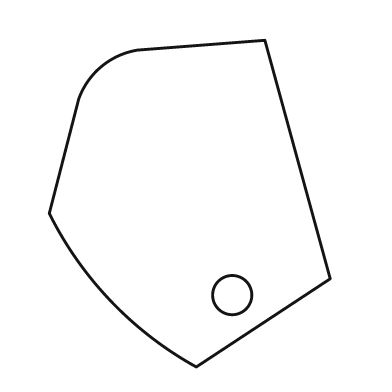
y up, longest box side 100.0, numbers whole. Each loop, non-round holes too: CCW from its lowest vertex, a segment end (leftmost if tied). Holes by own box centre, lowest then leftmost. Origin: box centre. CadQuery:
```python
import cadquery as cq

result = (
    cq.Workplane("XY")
    .moveTo(2.0, -50.0)
    .lineTo(43.0, -23.0)
    .lineTo(23.0, 50.0)
    .lineTo(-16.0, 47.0)
    .threePointArc((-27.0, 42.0), (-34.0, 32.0))
    .lineTo(-43.0, -3.0)
    .threePointArc((-24.0, -30.0), (2.0, -50.0))
    .close()
    .moveTo(13.0, -28.0)
    .circle(6.0)
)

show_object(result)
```